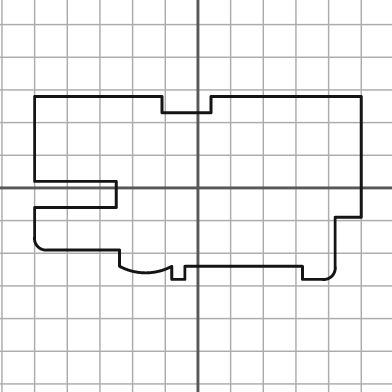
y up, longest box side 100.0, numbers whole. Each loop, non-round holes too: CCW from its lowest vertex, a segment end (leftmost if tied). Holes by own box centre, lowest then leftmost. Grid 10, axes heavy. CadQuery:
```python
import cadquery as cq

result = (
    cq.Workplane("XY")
    .moveTo(-8.0, -28.0)
    .lineTo(-4.0, -28.0)
    .lineTo(-4.0, -24.0)
    .lineTo(32.0, -24.0)
    .lineTo(32.0, -28.0)
    .lineTo(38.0, -28.0)
    .threePointArc((41.0, -27.0), (42.0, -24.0))
    .lineTo(42.0, -9.0)
    .lineTo(50.0, -9.0)
    .lineTo(50.0, 28.0)
    .lineTo(4.0, 28.0)
    .lineTo(4.0, 23.0)
    .lineTo(-11.0, 23.0)
    .lineTo(-11.0, 28.0)
    .lineTo(-50.0, 28.0)
    .lineTo(-50.0, 2.0)
    .lineTo(-25.0, 2.0)
    .lineTo(-25.0, -6.0)
    .lineTo(-50.0, -6.0)
    .lineTo(-50.0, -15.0)
    .threePointArc((-49.0, -18.0), (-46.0, -19.0))
    .lineTo(-24.0, -19.0)
    .lineTo(-24.0, -24.0)
    .threePointArc((-16.0, -26.0), (-8.0, -24.0))
    .close()
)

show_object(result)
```